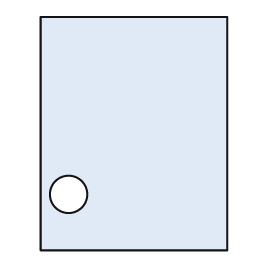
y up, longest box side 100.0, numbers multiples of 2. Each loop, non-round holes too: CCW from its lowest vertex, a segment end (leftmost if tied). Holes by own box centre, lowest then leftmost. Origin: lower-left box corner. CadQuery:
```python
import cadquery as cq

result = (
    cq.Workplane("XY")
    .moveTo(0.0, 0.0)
    .lineTo(80.0, 0.0)
    .lineTo(80.0, 100.0)
    .lineTo(0.0, 100.0)
    .close()
    .moveTo(12.0, 24.0)
    .circle(8.0)
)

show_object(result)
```